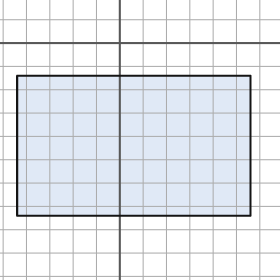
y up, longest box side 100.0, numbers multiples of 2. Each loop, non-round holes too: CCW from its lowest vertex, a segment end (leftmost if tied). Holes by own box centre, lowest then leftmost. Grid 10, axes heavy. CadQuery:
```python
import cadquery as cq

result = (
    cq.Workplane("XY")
    .moveTo(-44.0, -74.0)
    .lineTo(56.0, -74.0)
    .lineTo(56.0, -14.0)
    .lineTo(-44.0, -14.0)
    .close()
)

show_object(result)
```